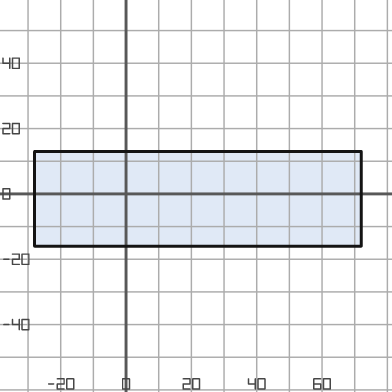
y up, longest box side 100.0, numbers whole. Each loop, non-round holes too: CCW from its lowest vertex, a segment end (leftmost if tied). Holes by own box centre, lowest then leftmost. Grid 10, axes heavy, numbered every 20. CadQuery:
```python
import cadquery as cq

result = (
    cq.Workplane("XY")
    .moveTo(-28.0, -16.0)
    .lineTo(72.0, -16.0)
    .lineTo(72.0, 13.0)
    .lineTo(-28.0, 13.0)
    .close()
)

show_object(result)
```